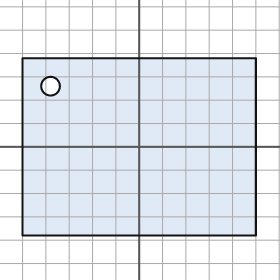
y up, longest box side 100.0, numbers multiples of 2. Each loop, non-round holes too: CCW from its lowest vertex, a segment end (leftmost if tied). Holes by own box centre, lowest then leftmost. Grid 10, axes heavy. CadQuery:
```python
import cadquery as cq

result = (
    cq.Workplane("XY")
    .moveTo(-50.0, -38.0)
    .lineTo(50.0, -38.0)
    .lineTo(50.0, 38.0)
    .lineTo(-50.0, 38.0)
    .close()
    .moveTo(-38.0, 26.0)
    .circle(4.0)
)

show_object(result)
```